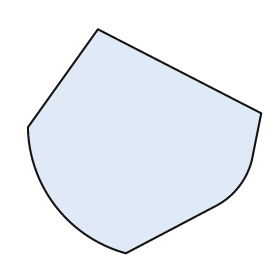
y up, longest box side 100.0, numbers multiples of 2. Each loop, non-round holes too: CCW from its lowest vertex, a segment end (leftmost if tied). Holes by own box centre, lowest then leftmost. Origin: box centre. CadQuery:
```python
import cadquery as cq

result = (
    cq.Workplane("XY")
    .moveTo(-8.0, -48.0)
    .lineTo(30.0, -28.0)
    .threePointArc((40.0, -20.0), (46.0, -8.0))
    .lineTo(50.0, 12.0)
    .lineTo(-20.0, 48.0)
    .lineTo(-50.0, 6.0)
    .threePointArc((-38.0, -28.0), (-8.0, -48.0))
    .close()
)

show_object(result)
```